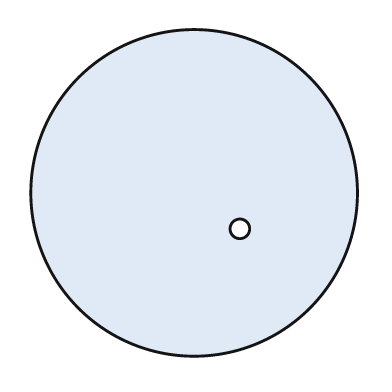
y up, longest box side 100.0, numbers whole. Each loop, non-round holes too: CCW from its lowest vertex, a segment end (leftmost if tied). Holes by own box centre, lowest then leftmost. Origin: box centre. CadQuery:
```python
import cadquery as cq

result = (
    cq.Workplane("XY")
    .moveTo(0.0, 0.0)
    .circle(50.0)
    .moveTo(14.0, -11.0)
    .circle(3.0)
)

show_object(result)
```